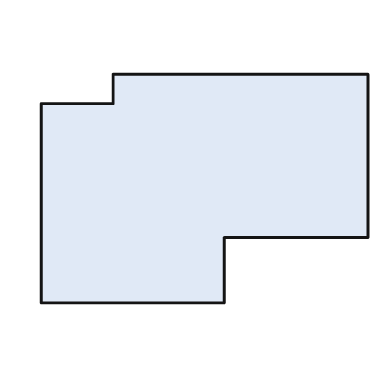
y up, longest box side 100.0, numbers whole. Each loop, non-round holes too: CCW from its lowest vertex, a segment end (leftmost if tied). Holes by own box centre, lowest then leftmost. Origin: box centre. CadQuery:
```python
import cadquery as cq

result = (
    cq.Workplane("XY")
    .moveTo(-50.0, -35.0)
    .lineTo(6.0, -35.0)
    .lineTo(6.0, -15.0)
    .lineTo(50.0, -15.0)
    .lineTo(50.0, 35.0)
    .lineTo(-28.0, 35.0)
    .lineTo(-28.0, 26.0)
    .lineTo(-50.0, 26.0)
    .close()
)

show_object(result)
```